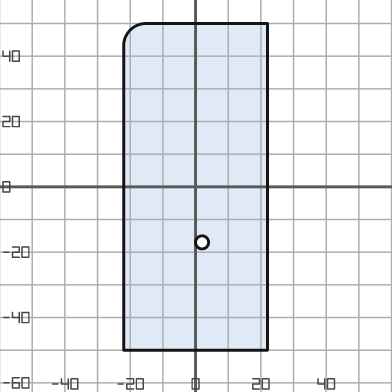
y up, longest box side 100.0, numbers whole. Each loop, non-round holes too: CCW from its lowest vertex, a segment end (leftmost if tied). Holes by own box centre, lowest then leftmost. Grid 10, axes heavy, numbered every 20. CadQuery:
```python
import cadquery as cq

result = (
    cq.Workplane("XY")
    .moveTo(-22.0, -50.0)
    .lineTo(22.0, -50.0)
    .lineTo(22.0, 50.0)
    .lineTo(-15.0, 50.0)
    .threePointArc((-20.0, 48.0), (-22.0, 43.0))
    .close()
    .moveTo(2.0, -17.0)
    .circle(2.0)
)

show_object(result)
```